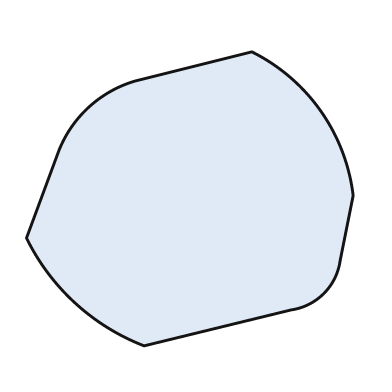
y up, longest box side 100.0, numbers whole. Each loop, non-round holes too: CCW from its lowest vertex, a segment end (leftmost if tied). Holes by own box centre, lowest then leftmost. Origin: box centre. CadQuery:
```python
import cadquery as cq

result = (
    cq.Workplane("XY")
    .moveTo(-14.0, -45.0)
    .lineTo(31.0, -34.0)
    .threePointArc((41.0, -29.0), (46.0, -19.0))
    .lineTo(50.0, 1.0)
    .threePointArc((40.0, 27.0), (19.0, 45.0))
    .lineTo(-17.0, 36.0)
    .threePointArc((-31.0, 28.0), (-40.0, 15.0))
    .lineTo(-50.0, -12.0)
    .threePointArc((-35.0, -32.0), (-14.0, -45.0))
    .close()
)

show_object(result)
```